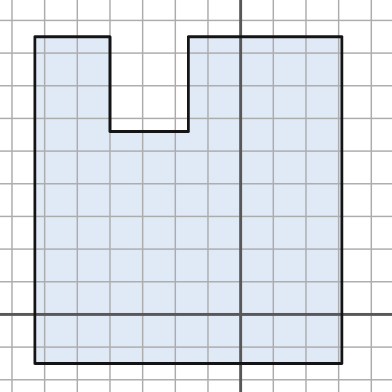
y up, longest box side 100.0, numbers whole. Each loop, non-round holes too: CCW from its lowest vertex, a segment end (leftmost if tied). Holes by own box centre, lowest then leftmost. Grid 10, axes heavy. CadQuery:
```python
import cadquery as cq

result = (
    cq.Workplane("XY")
    .moveTo(-63.0, -15.0)
    .lineTo(31.0, -15.0)
    .lineTo(31.0, 85.0)
    .lineTo(-16.0, 85.0)
    .lineTo(-16.0, 56.0)
    .lineTo(-40.0, 56.0)
    .lineTo(-40.0, 85.0)
    .lineTo(-63.0, 85.0)
    .close()
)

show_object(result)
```